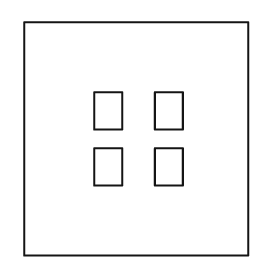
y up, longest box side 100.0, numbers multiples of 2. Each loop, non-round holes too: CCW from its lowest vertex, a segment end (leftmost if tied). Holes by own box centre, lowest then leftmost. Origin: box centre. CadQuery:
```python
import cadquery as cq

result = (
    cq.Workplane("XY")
    .moveTo(-48.0, -50.0)
    .lineTo(48.0, -50.0)
    .lineTo(48.0, 50.0)
    .lineTo(-48.0, 50.0)
    .close()
    .moveTo(-18.0, -20.0)
    .lineTo(-6.0, -20.0)
    .lineTo(-6.0, -4.0)
    .lineTo(-18.0, -4.0)
    .close()
    .moveTo(8.0, -20.0)
    .lineTo(20.0, -20.0)
    .lineTo(20.0, -4.0)
    .lineTo(8.0, -4.0)
    .close()
    .moveTo(-18.0, 4.0)
    .lineTo(-6.0, 4.0)
    .lineTo(-6.0, 20.0)
    .lineTo(-18.0, 20.0)
    .close()
    .moveTo(8.0, 4.0)
    .lineTo(20.0, 4.0)
    .lineTo(20.0, 20.0)
    .lineTo(8.0, 20.0)
    .close()
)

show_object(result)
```